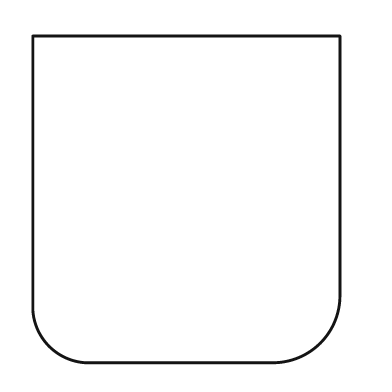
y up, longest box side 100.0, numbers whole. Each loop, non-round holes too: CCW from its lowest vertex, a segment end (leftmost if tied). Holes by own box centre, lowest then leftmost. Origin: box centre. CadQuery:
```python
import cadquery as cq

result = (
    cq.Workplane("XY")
    .moveTo(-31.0, -50.0)
    .lineTo(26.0, -50.0)
    .threePointArc((41.0, -44.0), (47.0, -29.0))
    .lineTo(47.0, 50.0)
    .lineTo(-47.0, 50.0)
    .lineTo(-47.0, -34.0)
    .threePointArc((-42.0, -45.0), (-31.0, -50.0))
    .close()
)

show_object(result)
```